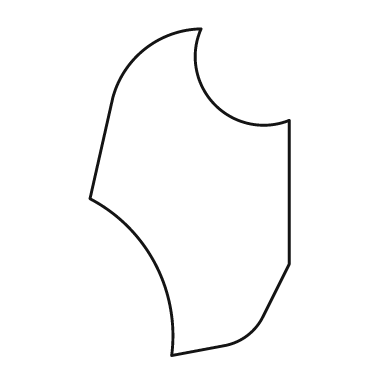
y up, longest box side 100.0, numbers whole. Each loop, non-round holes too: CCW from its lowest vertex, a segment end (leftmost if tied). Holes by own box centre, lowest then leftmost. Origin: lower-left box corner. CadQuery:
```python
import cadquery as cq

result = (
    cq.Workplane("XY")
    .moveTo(25.0, 0.0)
    .lineTo(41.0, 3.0)
    .threePointArc((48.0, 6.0), (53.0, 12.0))
    .lineTo(61.0, 28.0)
    .lineTo(61.0, 72.0)
    .threePointArc((38.0, 77.0), (34.0, 100.0))
    .threePointArc((17.0, 94.0), (7.0, 79.0))
    .lineTo(0.0, 48.0)
    .threePointArc((20.0, 28.0), (25.0, 0.0))
    .close()
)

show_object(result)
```